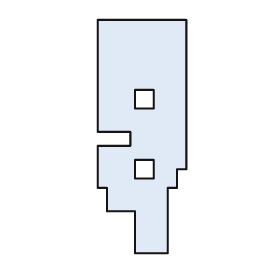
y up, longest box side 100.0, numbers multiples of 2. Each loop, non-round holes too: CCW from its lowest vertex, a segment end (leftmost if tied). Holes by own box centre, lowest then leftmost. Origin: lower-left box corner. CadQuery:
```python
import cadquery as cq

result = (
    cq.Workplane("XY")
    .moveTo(16.0, 0.0)
    .lineTo(30.0, 0.0)
    .lineTo(30.0, 28.0)
    .lineTo(34.0, 28.0)
    .lineTo(34.0, 36.0)
    .lineTo(38.0, 36.0)
    .lineTo(38.0, 100.0)
    .lineTo(0.0, 100.0)
    .lineTo(0.0, 52.0)
    .lineTo(14.0, 52.0)
    .lineTo(14.0, 46.0)
    .lineTo(0.0, 46.0)
    .lineTo(0.0, 28.0)
    .lineTo(4.0, 28.0)
    .lineTo(4.0, 18.0)
    .lineTo(16.0, 18.0)
    .close()
    .moveTo(16.0, 32.0)
    .lineTo(24.0, 32.0)
    .lineTo(24.0, 40.0)
    .lineTo(16.0, 40.0)
    .close()
    .moveTo(16.0, 62.0)
    .lineTo(24.0, 62.0)
    .lineTo(24.0, 70.0)
    .lineTo(16.0, 70.0)
    .close()
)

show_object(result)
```